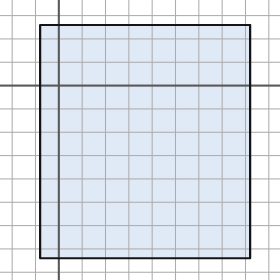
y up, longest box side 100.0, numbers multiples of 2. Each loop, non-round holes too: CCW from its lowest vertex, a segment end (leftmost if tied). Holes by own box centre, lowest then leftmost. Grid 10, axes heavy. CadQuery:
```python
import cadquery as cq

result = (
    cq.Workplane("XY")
    .moveTo(-8.0, -74.0)
    .lineTo(82.0, -74.0)
    .lineTo(82.0, 26.0)
    .lineTo(-8.0, 26.0)
    .close()
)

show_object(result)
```